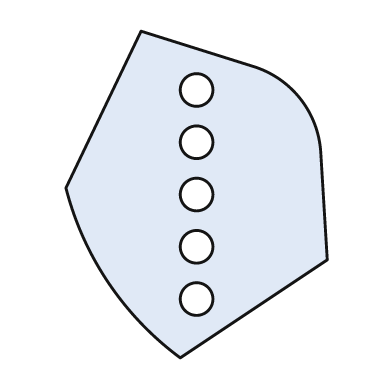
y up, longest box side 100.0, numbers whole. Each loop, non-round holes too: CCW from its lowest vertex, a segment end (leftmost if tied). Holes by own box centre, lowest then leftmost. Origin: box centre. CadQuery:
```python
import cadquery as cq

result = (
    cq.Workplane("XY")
    .moveTo(-5.0, -50.0)
    .lineTo(40.0, -20.0)
    .lineTo(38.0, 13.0)
    .threePointArc((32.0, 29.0), (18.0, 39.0))
    .lineTo(-17.0, 50.0)
    .lineTo(-40.0, 2.0)
    .threePointArc((-27.0, -27.0), (-5.0, -50.0))
    .close()
    .moveTo(0.0, -32.0)
    .circle(5.0)
    .moveTo(0.0, -16.0)
    .circle(5.0)
    .moveTo(0.0, 0.0)
    .circle(5.0)
    .moveTo(0.0, 16.0)
    .circle(5.0)
    .moveTo(0.0, 32.0)
    .circle(5.0)
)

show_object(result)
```